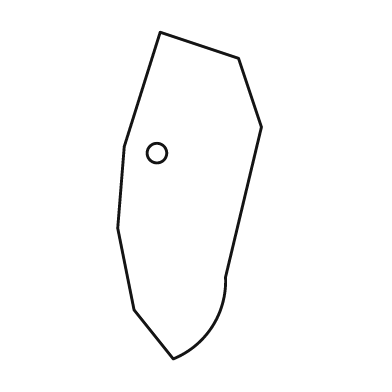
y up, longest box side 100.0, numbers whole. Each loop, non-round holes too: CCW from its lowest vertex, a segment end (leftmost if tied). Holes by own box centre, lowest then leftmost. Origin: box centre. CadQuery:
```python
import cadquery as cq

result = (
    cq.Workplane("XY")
    .moveTo(-5.0, -50.0)
    .threePointArc((7.0, -40.0), (11.0, -25.0))
    .lineTo(22.0, 21.0)
    .lineTo(15.0, 42.0)
    .lineTo(-9.0, 50.0)
    .lineTo(-20.0, 15.0)
    .lineTo(-22.0, -10.0)
    .lineTo(-17.0, -35.0)
    .close()
    .moveTo(-10.0, 13.0)
    .circle(3.0)
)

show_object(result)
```